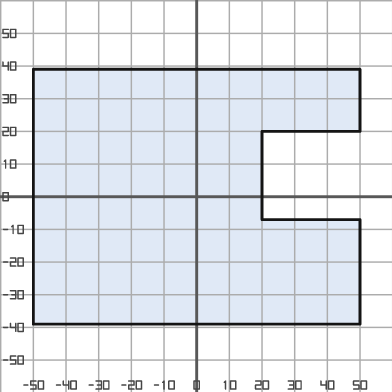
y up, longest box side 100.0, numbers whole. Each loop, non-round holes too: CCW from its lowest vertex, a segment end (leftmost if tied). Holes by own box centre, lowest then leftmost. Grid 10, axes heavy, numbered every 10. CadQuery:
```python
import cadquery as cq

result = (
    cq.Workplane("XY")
    .moveTo(-50.0, -39.0)
    .lineTo(50.0, -39.0)
    .lineTo(50.0, -7.0)
    .lineTo(20.0, -7.0)
    .lineTo(20.0, 20.0)
    .lineTo(50.0, 20.0)
    .lineTo(50.0, 39.0)
    .lineTo(-50.0, 39.0)
    .close()
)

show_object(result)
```